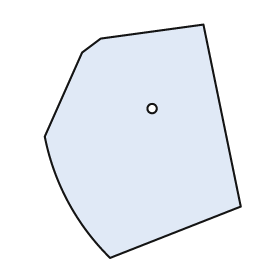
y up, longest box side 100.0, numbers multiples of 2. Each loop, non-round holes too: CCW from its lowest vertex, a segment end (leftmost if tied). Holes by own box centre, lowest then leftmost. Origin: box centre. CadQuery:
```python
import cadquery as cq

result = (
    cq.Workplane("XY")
    .moveTo(-14.0, -50.0)
    .lineTo(42.0, -28.0)
    .lineTo(26.0, 50.0)
    .lineTo(-18.0, 44.0)
    .lineTo(-26.0, 38.0)
    .lineTo(-42.0, 2.0)
    .threePointArc((-32.0, -26.0), (-14.0, -50.0))
    .close()
    .moveTo(4.0, 14.0)
    .circle(2.0)
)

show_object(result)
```